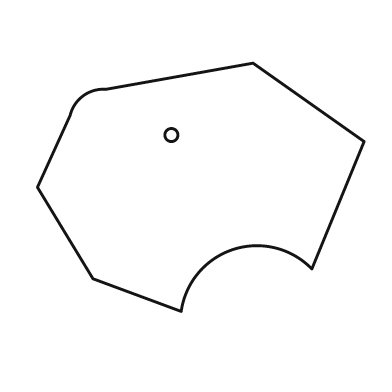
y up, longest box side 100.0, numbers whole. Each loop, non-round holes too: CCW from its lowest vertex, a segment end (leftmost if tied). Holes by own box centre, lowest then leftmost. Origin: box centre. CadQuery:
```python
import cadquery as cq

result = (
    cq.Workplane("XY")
    .moveTo(-6.0, -38.0)
    .threePointArc((10.0, -19.0), (34.0, -25.0))
    .lineTo(50.0, 14.0)
    .lineTo(16.0, 38.0)
    .lineTo(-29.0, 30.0)
    .threePointArc((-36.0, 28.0), (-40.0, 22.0))
    .lineTo(-50.0, 0.0)
    .lineTo(-33.0, -28.0)
    .close()
    .moveTo(-9.0, 16.0)
    .circle(2.0)
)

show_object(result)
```